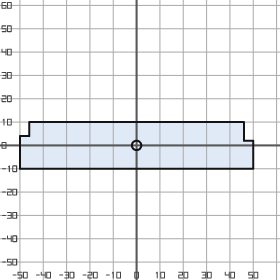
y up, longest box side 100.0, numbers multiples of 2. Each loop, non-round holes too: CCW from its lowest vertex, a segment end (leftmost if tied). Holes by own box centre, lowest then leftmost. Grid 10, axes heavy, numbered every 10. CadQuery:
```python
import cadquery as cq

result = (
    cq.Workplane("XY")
    .moveTo(-50.0, -10.0)
    .lineTo(50.0, -10.0)
    .lineTo(50.0, 2.0)
    .lineTo(46.0, 2.0)
    .lineTo(46.0, 10.0)
    .lineTo(-46.0, 10.0)
    .lineTo(-46.0, 4.0)
    .lineTo(-50.0, 4.0)
    .close()
    .moveTo(0.0, 0.0)
    .circle(2.0)
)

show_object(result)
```